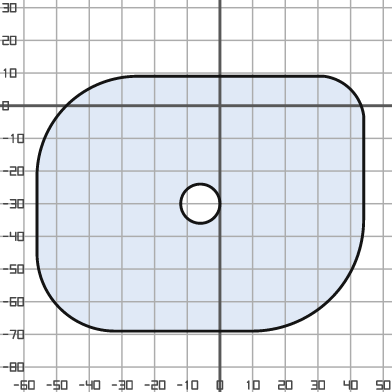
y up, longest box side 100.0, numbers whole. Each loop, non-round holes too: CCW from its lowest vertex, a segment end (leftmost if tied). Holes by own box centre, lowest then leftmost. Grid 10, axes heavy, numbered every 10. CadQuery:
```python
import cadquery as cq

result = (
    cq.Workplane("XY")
    .moveTo(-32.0, -69.0)
    .lineTo(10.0, -69.0)
    .threePointArc((34.0, -59.0), (44.0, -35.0))
    .lineTo(44.0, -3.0)
    .threePointArc((40.0, 5.0), (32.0, 9.0))
    .lineTo(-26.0, 9.0)
    .threePointArc((-47.0, 0.0), (-56.0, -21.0))
    .lineTo(-56.0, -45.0)
    .threePointArc((-49.0, -62.0), (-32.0, -69.0))
    .close()
    .moveTo(-6.0, -30.0)
    .circle(6.0)
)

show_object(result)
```